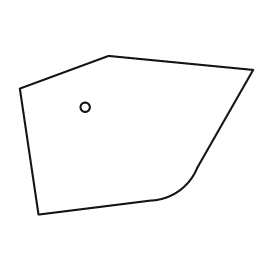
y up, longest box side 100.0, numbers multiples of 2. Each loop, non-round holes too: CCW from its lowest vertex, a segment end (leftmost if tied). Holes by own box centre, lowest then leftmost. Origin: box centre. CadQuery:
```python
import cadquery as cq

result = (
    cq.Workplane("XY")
    .moveTo(-42.0, -34.0)
    .lineTo(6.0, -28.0)
    .threePointArc((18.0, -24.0), (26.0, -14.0))
    .lineTo(50.0, 28.0)
    .lineTo(-12.0, 34.0)
    .lineTo(-50.0, 20.0)
    .close()
    .moveTo(-22.0, 12.0)
    .circle(2.0)
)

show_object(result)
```